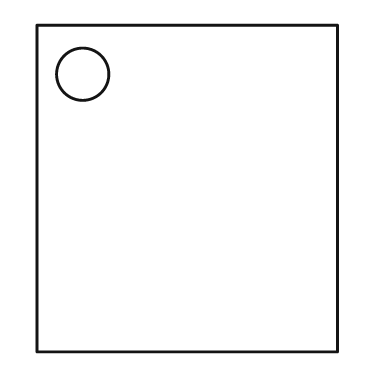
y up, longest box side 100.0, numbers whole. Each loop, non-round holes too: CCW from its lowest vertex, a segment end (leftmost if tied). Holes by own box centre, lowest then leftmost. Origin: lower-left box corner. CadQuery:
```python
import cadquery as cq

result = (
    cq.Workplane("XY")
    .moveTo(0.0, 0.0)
    .lineTo(92.0, 0.0)
    .lineTo(92.0, 100.0)
    .lineTo(0.0, 100.0)
    .close()
    .moveTo(14.0, 85.0)
    .circle(8.0)
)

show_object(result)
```